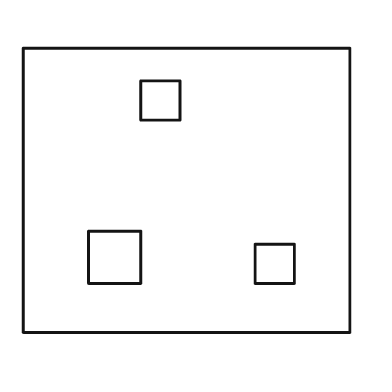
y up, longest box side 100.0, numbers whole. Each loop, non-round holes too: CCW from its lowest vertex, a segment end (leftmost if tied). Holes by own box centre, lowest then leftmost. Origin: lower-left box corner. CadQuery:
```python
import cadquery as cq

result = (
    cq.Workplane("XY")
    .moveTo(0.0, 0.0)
    .lineTo(100.0, 0.0)
    .lineTo(100.0, 87.0)
    .lineTo(0.0, 87.0)
    .close()
    .moveTo(71.0, 15.0)
    .lineTo(83.0, 15.0)
    .lineTo(83.0, 27.0)
    .lineTo(71.0, 27.0)
    .close()
    .moveTo(20.0, 15.0)
    .lineTo(36.0, 15.0)
    .lineTo(36.0, 31.0)
    .lineTo(20.0, 31.0)
    .close()
    .moveTo(36.0, 65.0)
    .lineTo(48.0, 65.0)
    .lineTo(48.0, 77.0)
    .lineTo(36.0, 77.0)
    .close()
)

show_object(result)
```